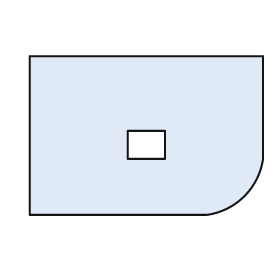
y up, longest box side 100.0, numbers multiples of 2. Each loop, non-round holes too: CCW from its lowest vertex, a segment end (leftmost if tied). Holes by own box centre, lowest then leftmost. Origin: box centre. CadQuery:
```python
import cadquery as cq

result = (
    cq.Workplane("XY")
    .moveTo(-50.0, -34.0)
    .lineTo(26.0, -34.0)
    .threePointArc((42.0, -26.0), (50.0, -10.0))
    .lineTo(50.0, 34.0)
    .lineTo(-50.0, 34.0)
    .close()
    .moveTo(-8.0, -10.0)
    .lineTo(8.0, -10.0)
    .lineTo(8.0, 2.0)
    .lineTo(-8.0, 2.0)
    .close()
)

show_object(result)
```